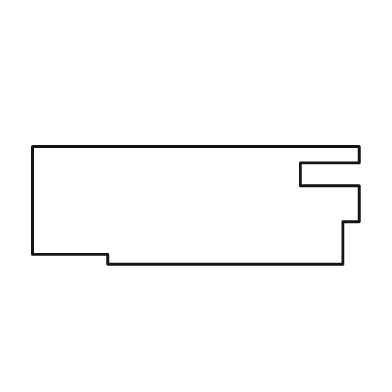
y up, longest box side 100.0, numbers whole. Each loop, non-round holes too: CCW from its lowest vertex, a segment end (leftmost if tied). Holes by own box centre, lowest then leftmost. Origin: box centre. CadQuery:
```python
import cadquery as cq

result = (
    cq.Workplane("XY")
    .moveTo(-27.0, -18.0)
    .lineTo(45.0, -18.0)
    .lineTo(45.0, -5.0)
    .lineTo(50.0, -5.0)
    .lineTo(50.0, 6.0)
    .lineTo(32.0, 6.0)
    .lineTo(32.0, 13.0)
    .lineTo(50.0, 13.0)
    .lineTo(50.0, 18.0)
    .lineTo(-50.0, 18.0)
    .lineTo(-50.0, -15.0)
    .lineTo(-27.0, -15.0)
    .close()
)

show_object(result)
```